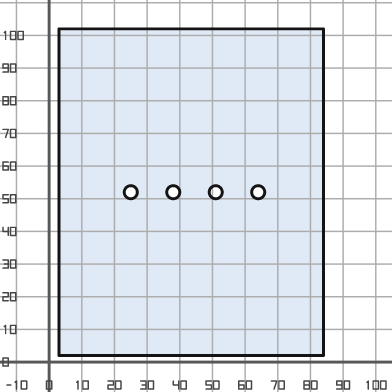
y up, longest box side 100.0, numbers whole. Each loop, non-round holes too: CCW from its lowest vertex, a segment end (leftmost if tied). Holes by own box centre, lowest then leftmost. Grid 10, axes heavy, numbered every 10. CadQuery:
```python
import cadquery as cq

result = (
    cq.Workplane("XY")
    .moveTo(3.0, 2.0)
    .lineTo(84.0, 2.0)
    .lineTo(84.0, 102.0)
    .lineTo(3.0, 102.0)
    .close()
    .moveTo(25.0, 52.0)
    .circle(2.0)
    .moveTo(38.0, 52.0)
    .circle(2.0)
    .moveTo(51.0, 52.0)
    .circle(2.0)
    .moveTo(64.0, 52.0)
    .circle(2.0)
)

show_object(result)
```